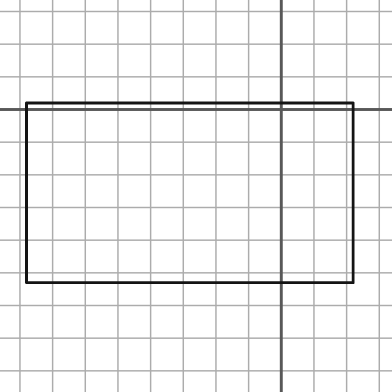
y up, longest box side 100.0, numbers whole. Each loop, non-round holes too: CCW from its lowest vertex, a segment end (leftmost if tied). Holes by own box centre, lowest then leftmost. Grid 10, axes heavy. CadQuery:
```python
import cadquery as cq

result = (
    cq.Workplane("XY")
    .moveTo(-78.0, -53.0)
    .lineTo(22.0, -53.0)
    .lineTo(22.0, 2.0)
    .lineTo(-78.0, 2.0)
    .close()
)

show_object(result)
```